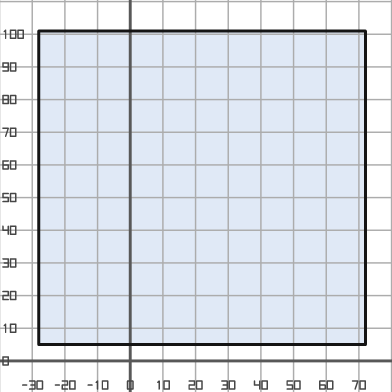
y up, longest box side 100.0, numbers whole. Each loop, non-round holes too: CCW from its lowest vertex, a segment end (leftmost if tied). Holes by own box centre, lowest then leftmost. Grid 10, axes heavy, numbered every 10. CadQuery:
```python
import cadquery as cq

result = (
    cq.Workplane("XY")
    .moveTo(-28.0, 5.0)
    .lineTo(72.0, 5.0)
    .lineTo(72.0, 101.0)
    .lineTo(-28.0, 101.0)
    .close()
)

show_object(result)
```